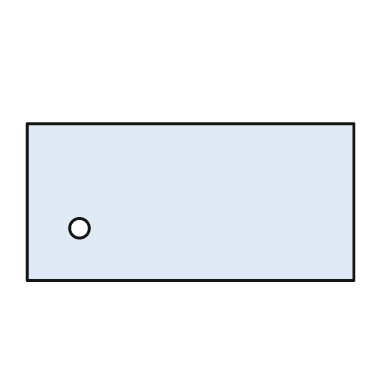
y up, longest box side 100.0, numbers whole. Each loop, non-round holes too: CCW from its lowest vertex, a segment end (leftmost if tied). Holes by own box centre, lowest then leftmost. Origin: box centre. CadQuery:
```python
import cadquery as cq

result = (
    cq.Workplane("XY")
    .moveTo(-50.0, -24.0)
    .lineTo(50.0, -24.0)
    .lineTo(50.0, 24.0)
    .lineTo(-50.0, 24.0)
    .close()
    .moveTo(-34.0, -8.0)
    .circle(3.0)
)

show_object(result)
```